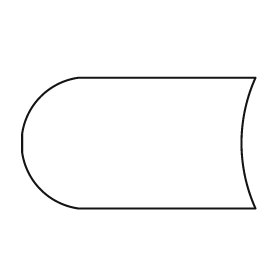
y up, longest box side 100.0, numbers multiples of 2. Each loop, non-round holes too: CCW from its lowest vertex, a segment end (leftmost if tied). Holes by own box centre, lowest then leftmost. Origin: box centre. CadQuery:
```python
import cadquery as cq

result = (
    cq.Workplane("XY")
    .moveTo(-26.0, -28.0)
    .lineTo(50.0, -28.0)
    .threePointArc((44.0, 0.0), (50.0, 28.0))
    .lineTo(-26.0, 28.0)
    .threePointArc((-42.0, 20.0), (-50.0, 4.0))
    .lineTo(-50.0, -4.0)
    .threePointArc((-42.0, -20.0), (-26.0, -28.0))
    .close()
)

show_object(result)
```